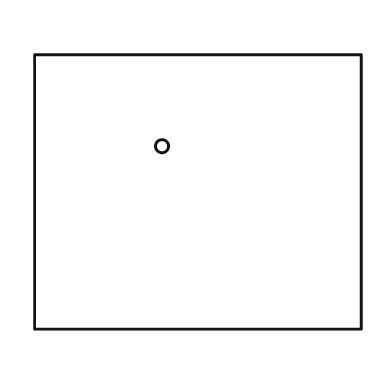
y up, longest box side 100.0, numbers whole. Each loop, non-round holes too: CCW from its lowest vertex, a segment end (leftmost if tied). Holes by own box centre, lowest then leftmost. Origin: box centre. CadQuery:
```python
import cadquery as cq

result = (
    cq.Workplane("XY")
    .moveTo(-50.0, -42.0)
    .lineTo(50.0, -42.0)
    .lineTo(50.0, 42.0)
    .lineTo(-50.0, 42.0)
    .close()
    .moveTo(-11.0, 14.0)
    .circle(2.0)
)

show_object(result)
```